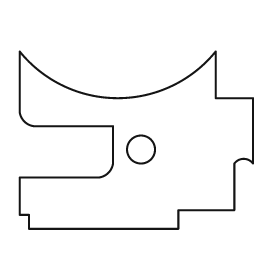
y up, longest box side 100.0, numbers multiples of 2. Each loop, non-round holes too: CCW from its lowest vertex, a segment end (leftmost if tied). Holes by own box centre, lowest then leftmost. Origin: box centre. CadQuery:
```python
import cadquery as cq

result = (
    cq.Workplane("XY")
    .moveTo(-46.0, -38.0)
    .lineTo(18.0, -38.0)
    .lineTo(18.0, -30.0)
    .lineTo(42.0, -30.0)
    .lineTo(42.0, -10.0)
    .threePointArc((46.0, -8.0), (50.0, -10.0))
    .lineTo(50.0, 18.0)
    .lineTo(34.0, 18.0)
    .lineTo(34.0, 38.0)
    .threePointArc((-8.0, 18.0), (-50.0, 38.0))
    .lineTo(-50.0, 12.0)
    .threePointArc((-48.0, 8.0), (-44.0, 6.0))
    .lineTo(-10.0, 6.0)
    .lineTo(-10.0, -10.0)
    .threePointArc((-12.0, -14.0), (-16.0, -16.0))
    .lineTo(-50.0, -16.0)
    .lineTo(-50.0, -32.0)
    .lineTo(-46.0, -32.0)
    .close()
    .moveTo(2.0, -4.0)
    .circle(6.0)
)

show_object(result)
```